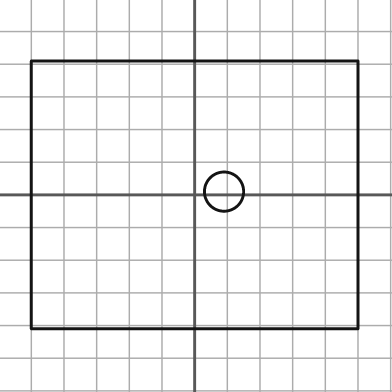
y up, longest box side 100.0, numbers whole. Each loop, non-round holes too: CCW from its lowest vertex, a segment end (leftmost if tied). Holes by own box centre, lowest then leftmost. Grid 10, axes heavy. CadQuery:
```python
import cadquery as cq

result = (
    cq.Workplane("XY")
    .moveTo(-50.0, -41.0)
    .lineTo(50.0, -41.0)
    .lineTo(50.0, 41.0)
    .lineTo(-50.0, 41.0)
    .close()
    .moveTo(9.0, 1.0)
    .circle(6.0)
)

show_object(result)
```